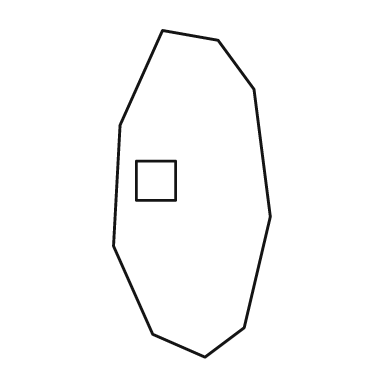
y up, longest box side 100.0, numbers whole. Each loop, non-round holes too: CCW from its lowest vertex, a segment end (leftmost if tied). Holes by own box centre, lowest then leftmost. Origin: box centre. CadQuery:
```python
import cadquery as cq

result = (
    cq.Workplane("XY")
    .moveTo(4.0, -50.0)
    .lineTo(16.0, -41.0)
    .lineTo(24.0, -7.0)
    .lineTo(19.0, 32.0)
    .lineTo(8.0, 47.0)
    .lineTo(-9.0, 50.0)
    .lineTo(-22.0, 21.0)
    .lineTo(-24.0, -16.0)
    .lineTo(-12.0, -43.0)
    .close()
    .moveTo(-17.0, -2.0)
    .lineTo(-5.0, -2.0)
    .lineTo(-5.0, 10.0)
    .lineTo(-17.0, 10.0)
    .close()
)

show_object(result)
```